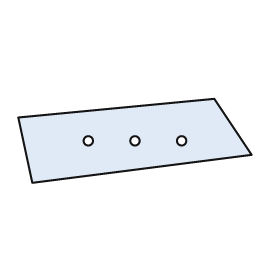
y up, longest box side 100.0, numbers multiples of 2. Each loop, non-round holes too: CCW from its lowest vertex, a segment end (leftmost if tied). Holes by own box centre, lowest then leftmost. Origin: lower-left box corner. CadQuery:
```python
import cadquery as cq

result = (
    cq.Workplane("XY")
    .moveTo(6.0, 0.0)
    .lineTo(100.0, 12.0)
    .lineTo(84.0, 36.0)
    .lineTo(0.0, 28.0)
    .close()
    .moveTo(30.0, 18.0)
    .circle(2.0)
    .moveTo(50.0, 18.0)
    .circle(2.0)
    .moveTo(70.0, 18.0)
    .circle(2.0)
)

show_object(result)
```